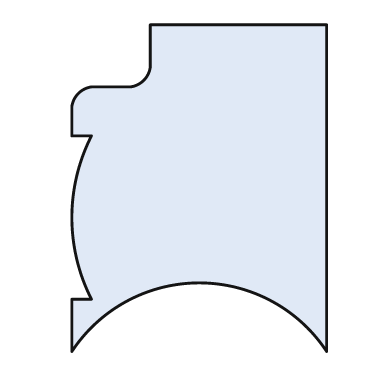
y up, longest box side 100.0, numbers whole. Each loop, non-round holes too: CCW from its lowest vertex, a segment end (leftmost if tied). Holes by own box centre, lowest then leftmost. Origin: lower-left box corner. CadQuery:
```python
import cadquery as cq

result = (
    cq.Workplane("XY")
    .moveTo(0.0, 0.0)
    .threePointArc((39.0, 21.0), (78.0, 0.0))
    .lineTo(78.0, 100.0)
    .lineTo(24.0, 100.0)
    .lineTo(24.0, 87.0)
    .threePointArc((22.0, 83.0), (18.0, 81.0))
    .lineTo(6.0, 81.0)
    .threePointArc((2.0, 79.0), (0.0, 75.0))
    .lineTo(0.0, 66.0)
    .lineTo(6.0, 66.0)
    .threePointArc((0.0, 41.0), (6.0, 16.0))
    .lineTo(0.0, 16.0)
    .close()
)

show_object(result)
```